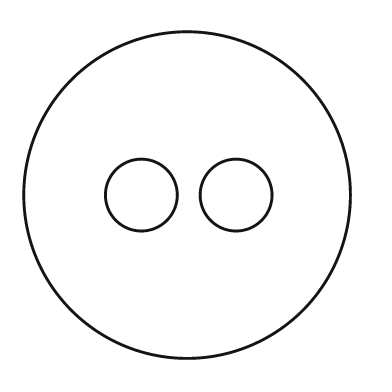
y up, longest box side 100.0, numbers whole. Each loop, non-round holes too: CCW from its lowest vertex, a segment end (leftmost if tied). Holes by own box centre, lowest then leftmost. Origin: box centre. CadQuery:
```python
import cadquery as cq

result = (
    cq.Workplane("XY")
    .moveTo(0.0, 0.0)
    .circle(50.0)
    .moveTo(-14.0, 0.0)
    .circle(11.0)
    .moveTo(15.0, 0.0)
    .circle(11.0)
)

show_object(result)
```